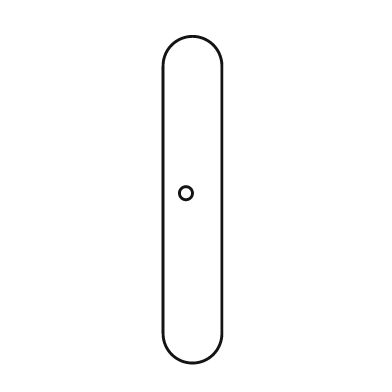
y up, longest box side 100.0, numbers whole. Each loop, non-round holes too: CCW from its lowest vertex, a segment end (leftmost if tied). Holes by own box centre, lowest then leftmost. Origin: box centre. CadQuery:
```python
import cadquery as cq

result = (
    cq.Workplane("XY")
    .moveTo(-9.0, -41.0)
    .threePointArc((0.0, -50.0), (9.0, -41.0))
    .lineTo(9.0, 41.0)
    .threePointArc((0.0, 50.0), (-9.0, 41.0))
    .close()
    .moveTo(-2.0, 2.0)
    .circle(2.0)
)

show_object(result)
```